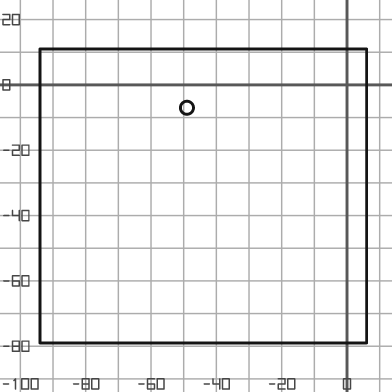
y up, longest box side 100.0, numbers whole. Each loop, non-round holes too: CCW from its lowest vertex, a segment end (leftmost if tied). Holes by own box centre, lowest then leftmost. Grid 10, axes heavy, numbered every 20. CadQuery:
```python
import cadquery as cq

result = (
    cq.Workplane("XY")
    .moveTo(-94.0, -79.0)
    .lineTo(6.0, -79.0)
    .lineTo(6.0, 11.0)
    .lineTo(-94.0, 11.0)
    .close()
    .moveTo(-49.0, -7.0)
    .circle(2.0)
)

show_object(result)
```